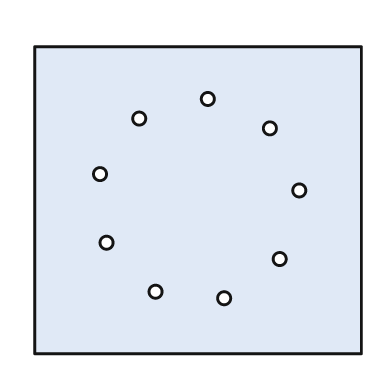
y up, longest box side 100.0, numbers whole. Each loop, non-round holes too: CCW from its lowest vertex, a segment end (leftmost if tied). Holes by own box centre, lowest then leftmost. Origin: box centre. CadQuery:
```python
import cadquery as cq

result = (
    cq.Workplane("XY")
    .moveTo(-50.0, -47.0)
    .lineTo(50.0, -47.0)
    .lineTo(50.0, 47.0)
    .lineTo(-50.0, 47.0)
    .close()
    .moveTo(8.0, -30.0)
    .circle(2.0)
    .moveTo(-13.0, -28.0)
    .circle(2.0)
    .moveTo(25.0, -18.0)
    .circle(2.0)
    .moveTo(-28.0, -13.0)
    .circle(2.0)
    .moveTo(31.0, 3.0)
    .circle(2.0)
    .moveTo(-30.0, 8.0)
    .circle(2.0)
    .moveTo(22.0, 22.0)
    .circle(2.0)
    .moveTo(-18.0, 25.0)
    .circle(2.0)
    .moveTo(3.0, 31.0)
    .circle(2.0)
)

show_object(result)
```